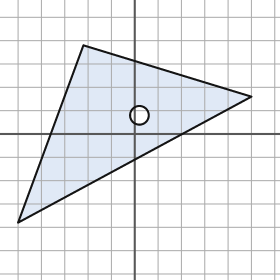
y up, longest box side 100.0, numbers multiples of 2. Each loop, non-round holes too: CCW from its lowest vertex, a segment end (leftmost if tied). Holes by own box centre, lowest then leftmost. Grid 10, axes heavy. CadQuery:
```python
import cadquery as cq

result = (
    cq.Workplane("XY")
    .moveTo(-50.0, -38.0)
    .lineTo(50.0, 16.0)
    .lineTo(-22.0, 38.0)
    .close()
    .moveTo(2.0, 8.0)
    .circle(4.0)
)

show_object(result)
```